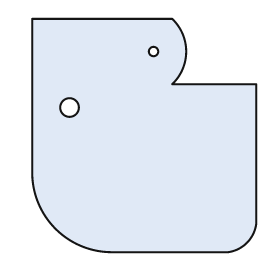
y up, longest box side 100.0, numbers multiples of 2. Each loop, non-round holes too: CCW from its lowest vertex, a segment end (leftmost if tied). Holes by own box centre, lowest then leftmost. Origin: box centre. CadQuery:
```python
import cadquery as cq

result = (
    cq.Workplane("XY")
    .moveTo(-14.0, -50.0)
    .lineTo(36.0, -50.0)
    .threePointArc((44.0, -46.0), (48.0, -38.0))
    .lineTo(48.0, 22.0)
    .lineTo(12.0, 22.0)
    .threePointArc((18.0, 36.0), (12.0, 50.0))
    .lineTo(-48.0, 50.0)
    .lineTo(-48.0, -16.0)
    .threePointArc((-38.0, -40.0), (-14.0, -50.0))
    .close()
    .moveTo(-32.0, 12.0)
    .circle(4.0)
    .moveTo(4.0, 36.0)
    .circle(2.0)
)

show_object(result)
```